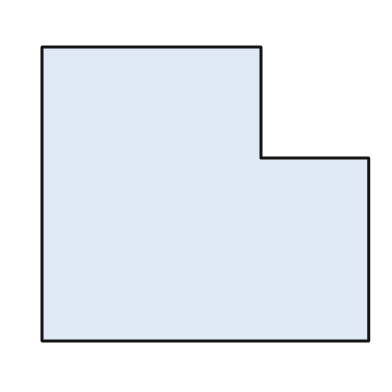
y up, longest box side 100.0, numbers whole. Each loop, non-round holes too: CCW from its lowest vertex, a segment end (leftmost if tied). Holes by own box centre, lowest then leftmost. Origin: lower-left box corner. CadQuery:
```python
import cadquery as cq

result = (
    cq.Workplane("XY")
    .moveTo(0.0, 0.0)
    .lineTo(100.0, 0.0)
    .lineTo(100.0, 56.0)
    .lineTo(67.0, 56.0)
    .lineTo(67.0, 90.0)
    .lineTo(0.0, 90.0)
    .close()
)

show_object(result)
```